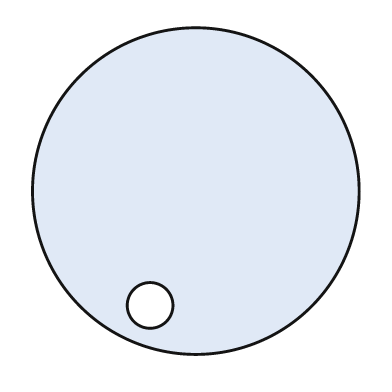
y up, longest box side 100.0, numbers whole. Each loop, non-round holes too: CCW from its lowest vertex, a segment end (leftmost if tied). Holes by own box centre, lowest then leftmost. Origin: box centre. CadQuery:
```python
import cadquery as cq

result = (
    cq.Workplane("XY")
    .moveTo(0.0, 0.0)
    .circle(50.0)
    .moveTo(-14.0, -35.0)
    .circle(7.0)
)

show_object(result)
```